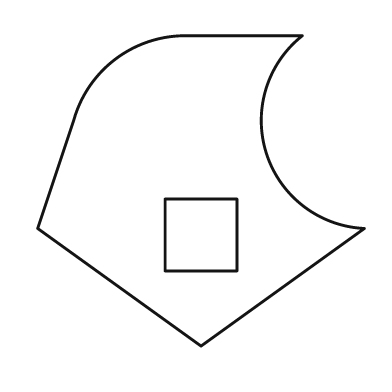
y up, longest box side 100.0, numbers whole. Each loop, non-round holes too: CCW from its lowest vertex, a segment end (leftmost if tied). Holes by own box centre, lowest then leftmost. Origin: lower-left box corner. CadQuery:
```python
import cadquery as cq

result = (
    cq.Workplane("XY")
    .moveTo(50.0, 0.0)
    .lineTo(100.0, 36.0)
    .threePointArc((70.0, 59.0), (81.0, 95.0))
    .lineTo(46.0, 95.0)
    .threePointArc((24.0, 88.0), (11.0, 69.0))
    .lineTo(0.0, 36.0)
    .close()
    .moveTo(39.0, 23.0)
    .lineTo(61.0, 23.0)
    .lineTo(61.0, 45.0)
    .lineTo(39.0, 45.0)
    .close()
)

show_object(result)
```